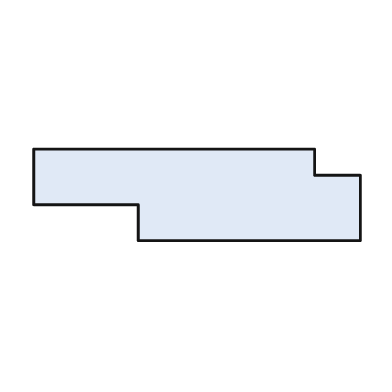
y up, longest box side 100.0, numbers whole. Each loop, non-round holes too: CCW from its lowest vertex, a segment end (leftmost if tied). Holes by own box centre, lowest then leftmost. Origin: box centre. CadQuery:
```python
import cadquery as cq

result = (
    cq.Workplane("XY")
    .moveTo(-18.0, -14.0)
    .lineTo(50.0, -14.0)
    .lineTo(50.0, 6.0)
    .lineTo(36.0, 6.0)
    .lineTo(36.0, 14.0)
    .lineTo(-50.0, 14.0)
    .lineTo(-50.0, -3.0)
    .lineTo(-18.0, -3.0)
    .close()
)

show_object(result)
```